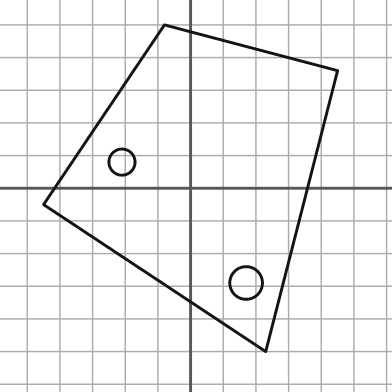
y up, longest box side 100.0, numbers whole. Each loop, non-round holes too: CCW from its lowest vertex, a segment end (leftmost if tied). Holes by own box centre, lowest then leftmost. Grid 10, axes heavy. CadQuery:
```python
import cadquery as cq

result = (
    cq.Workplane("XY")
    .moveTo(23.0, -50.0)
    .lineTo(45.0, 36.0)
    .lineTo(-8.0, 50.0)
    .lineTo(-45.0, -5.0)
    .close()
    .moveTo(17.0, -29.0)
    .circle(5.0)
    .moveTo(-21.0, 8.0)
    .circle(4.0)
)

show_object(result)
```